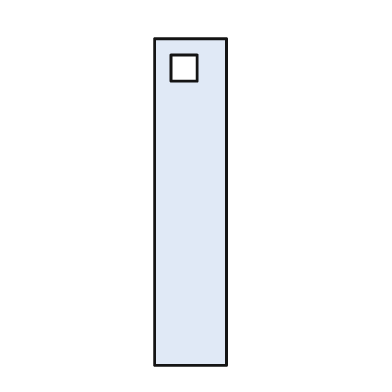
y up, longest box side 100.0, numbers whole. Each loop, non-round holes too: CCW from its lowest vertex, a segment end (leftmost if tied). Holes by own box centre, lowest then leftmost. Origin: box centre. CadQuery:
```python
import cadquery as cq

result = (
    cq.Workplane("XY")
    .moveTo(-11.0, -50.0)
    .lineTo(11.0, -50.0)
    .lineTo(11.0, 50.0)
    .lineTo(-11.0, 50.0)
    .close()
    .moveTo(-6.0, 37.0)
    .lineTo(2.0, 37.0)
    .lineTo(2.0, 45.0)
    .lineTo(-6.0, 45.0)
    .close()
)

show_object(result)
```